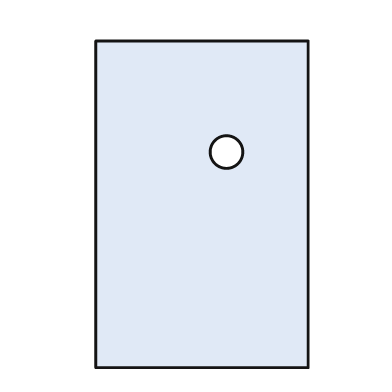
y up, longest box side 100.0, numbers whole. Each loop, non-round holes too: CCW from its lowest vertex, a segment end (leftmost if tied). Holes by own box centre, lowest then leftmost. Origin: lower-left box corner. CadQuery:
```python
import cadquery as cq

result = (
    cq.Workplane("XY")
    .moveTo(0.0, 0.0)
    .lineTo(65.0, 0.0)
    .lineTo(65.0, 100.0)
    .lineTo(0.0, 100.0)
    .close()
    .moveTo(40.0, 66.0)
    .circle(5.0)
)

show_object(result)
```